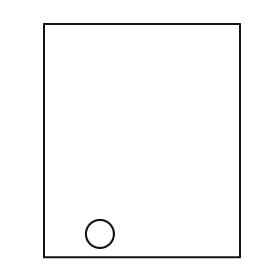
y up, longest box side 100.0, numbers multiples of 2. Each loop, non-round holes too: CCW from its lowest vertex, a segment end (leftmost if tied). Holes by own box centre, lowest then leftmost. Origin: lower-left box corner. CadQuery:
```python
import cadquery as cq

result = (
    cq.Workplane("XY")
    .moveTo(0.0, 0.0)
    .lineTo(84.0, 0.0)
    .lineTo(84.0, 100.0)
    .lineTo(0.0, 100.0)
    .close()
    .moveTo(24.0, 10.0)
    .circle(6.0)
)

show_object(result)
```